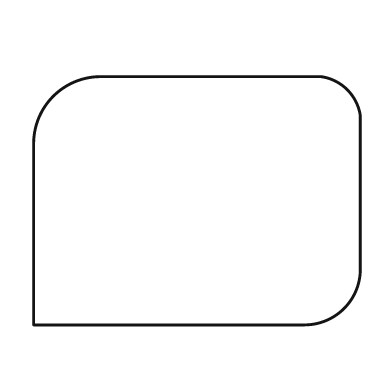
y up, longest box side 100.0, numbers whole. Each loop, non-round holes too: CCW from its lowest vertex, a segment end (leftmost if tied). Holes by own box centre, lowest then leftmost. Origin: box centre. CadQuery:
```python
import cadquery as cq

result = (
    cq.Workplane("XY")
    .moveTo(-50.0, -38.0)
    .lineTo(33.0, -38.0)
    .threePointArc((45.0, -33.0), (50.0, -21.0))
    .lineTo(50.0, 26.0)
    .threePointArc((46.0, 34.0), (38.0, 38.0))
    .lineTo(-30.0, 38.0)
    .threePointArc((-44.0, 32.0), (-50.0, 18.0))
    .close()
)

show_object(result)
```